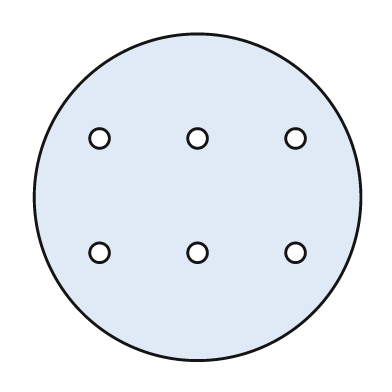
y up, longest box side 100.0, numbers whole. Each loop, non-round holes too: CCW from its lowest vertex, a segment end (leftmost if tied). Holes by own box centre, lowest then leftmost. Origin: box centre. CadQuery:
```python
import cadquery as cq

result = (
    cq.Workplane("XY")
    .moveTo(0.0, 0.0)
    .circle(50.0)
    .moveTo(-30.0, -17.0)
    .circle(3.0)
    .moveTo(0.0, -17.0)
    .circle(3.0)
    .moveTo(30.0, -17.0)
    .circle(3.0)
    .moveTo(-30.0, 18.0)
    .circle(3.0)
    .moveTo(0.0, 18.0)
    .circle(3.0)
    .moveTo(30.0, 18.0)
    .circle(3.0)
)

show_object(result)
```